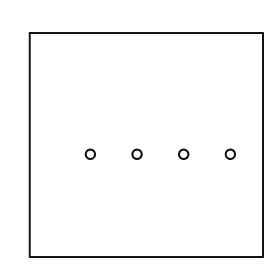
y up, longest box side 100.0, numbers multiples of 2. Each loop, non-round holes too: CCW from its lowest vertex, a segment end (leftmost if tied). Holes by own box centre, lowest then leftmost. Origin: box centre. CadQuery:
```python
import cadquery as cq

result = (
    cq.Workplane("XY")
    .moveTo(-50.0, -48.0)
    .lineTo(50.0, -48.0)
    .lineTo(50.0, 48.0)
    .lineTo(-50.0, 48.0)
    .close()
    .moveTo(-24.0, -4.0)
    .circle(2.0)
    .moveTo(-4.0, -4.0)
    .circle(2.0)
    .moveTo(16.0, -4.0)
    .circle(2.0)
    .moveTo(36.0, -4.0)
    .circle(2.0)
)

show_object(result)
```